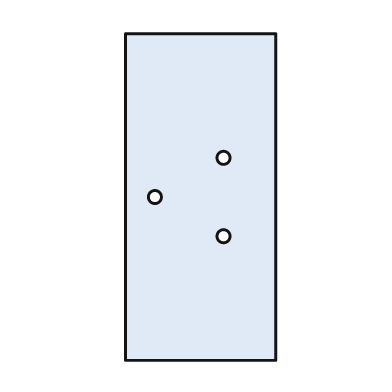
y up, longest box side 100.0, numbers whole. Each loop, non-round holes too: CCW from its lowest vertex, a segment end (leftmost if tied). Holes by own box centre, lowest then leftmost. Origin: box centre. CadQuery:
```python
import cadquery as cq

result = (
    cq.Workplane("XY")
    .moveTo(-23.0, -50.0)
    .lineTo(23.0, -50.0)
    .lineTo(23.0, 50.0)
    .lineTo(-23.0, 50.0)
    .close()
    .moveTo(7.0, -12.0)
    .circle(2.0)
    .moveTo(-14.0, 0.0)
    .circle(2.0)
    .moveTo(7.0, 12.0)
    .circle(2.0)
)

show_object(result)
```